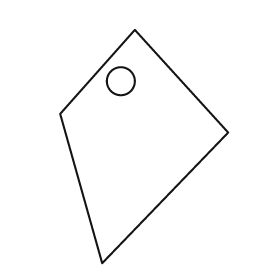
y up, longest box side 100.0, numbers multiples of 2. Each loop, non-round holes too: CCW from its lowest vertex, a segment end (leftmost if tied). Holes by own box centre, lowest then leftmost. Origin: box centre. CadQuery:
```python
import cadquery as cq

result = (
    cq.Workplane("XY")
    .moveTo(-18.0, -50.0)
    .lineTo(36.0, 6.0)
    .lineTo(-4.0, 50.0)
    .lineTo(-36.0, 14.0)
    .close()
    .moveTo(-10.0, 28.0)
    .circle(6.0)
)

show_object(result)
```